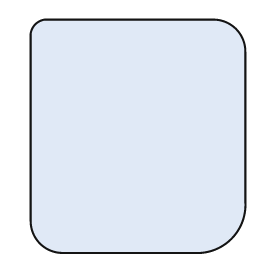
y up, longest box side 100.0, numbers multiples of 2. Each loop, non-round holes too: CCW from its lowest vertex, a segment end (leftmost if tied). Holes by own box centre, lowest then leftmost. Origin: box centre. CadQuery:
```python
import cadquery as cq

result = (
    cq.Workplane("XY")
    .moveTo(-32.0, -50.0)
    .lineTo(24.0, -50.0)
    .threePointArc((40.0, -44.0), (46.0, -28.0))
    .lineTo(46.0, 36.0)
    .threePointArc((42.0, 46.0), (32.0, 50.0))
    .lineTo(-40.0, 50.0)
    .threePointArc((-44.0, 48.0), (-46.0, 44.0))
    .lineTo(-46.0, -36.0)
    .threePointArc((-42.0, -46.0), (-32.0, -50.0))
    .close()
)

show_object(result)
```